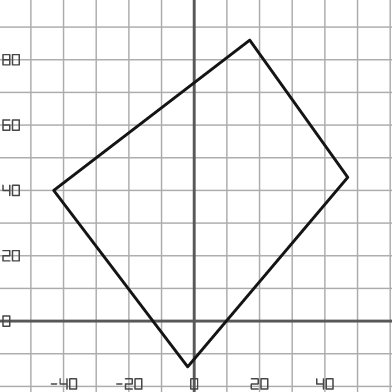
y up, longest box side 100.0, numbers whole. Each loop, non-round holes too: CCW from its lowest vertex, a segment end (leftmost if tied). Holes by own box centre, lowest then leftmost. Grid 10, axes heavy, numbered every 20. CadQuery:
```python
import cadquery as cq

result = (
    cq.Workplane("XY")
    .moveTo(-2.0, -14.0)
    .lineTo(47.0, 44.0)
    .lineTo(17.0, 86.0)
    .lineTo(-43.0, 40.0)
    .close()
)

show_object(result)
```